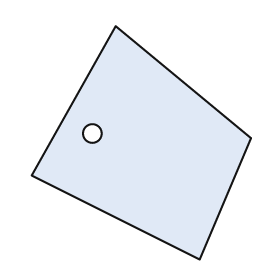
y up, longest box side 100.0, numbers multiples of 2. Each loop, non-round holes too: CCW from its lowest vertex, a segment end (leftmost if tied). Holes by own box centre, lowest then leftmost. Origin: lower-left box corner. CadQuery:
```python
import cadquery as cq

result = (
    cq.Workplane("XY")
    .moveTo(72.0, 0.0)
    .lineTo(94.0, 52.0)
    .lineTo(36.0, 100.0)
    .lineTo(0.0, 36.0)
    .close()
    .moveTo(26.0, 54.0)
    .circle(4.0)
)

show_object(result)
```